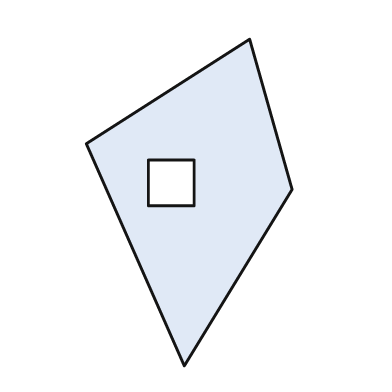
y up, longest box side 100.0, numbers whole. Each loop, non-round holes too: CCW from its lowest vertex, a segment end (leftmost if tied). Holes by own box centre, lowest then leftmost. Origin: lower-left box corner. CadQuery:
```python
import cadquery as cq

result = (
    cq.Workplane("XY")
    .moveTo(30.0, 0.0)
    .lineTo(63.0, 54.0)
    .lineTo(50.0, 100.0)
    .lineTo(0.0, 68.0)
    .close()
    .moveTo(19.0, 49.0)
    .lineTo(33.0, 49.0)
    .lineTo(33.0, 63.0)
    .lineTo(19.0, 63.0)
    .close()
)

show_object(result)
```